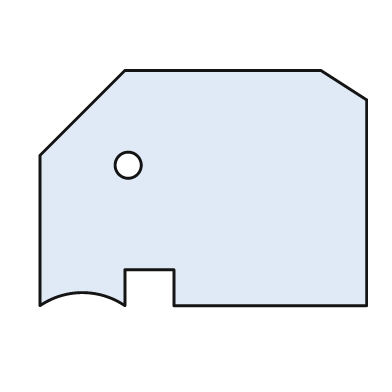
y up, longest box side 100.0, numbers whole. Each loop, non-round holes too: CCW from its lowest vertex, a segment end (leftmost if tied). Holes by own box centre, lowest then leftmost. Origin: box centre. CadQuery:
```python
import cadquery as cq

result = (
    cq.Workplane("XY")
    .moveTo(-50.0, -36.0)
    .threePointArc((-37.0, -32.0), (-24.0, -36.0))
    .lineTo(-24.0, -25.0)
    .lineTo(-9.0, -25.0)
    .lineTo(-9.0, -36.0)
    .lineTo(50.0, -36.0)
    .lineTo(50.0, 27.0)
    .lineTo(36.0, 36.0)
    .lineTo(-24.0, 36.0)
    .lineTo(-50.0, 10.0)
    .close()
    .moveTo(-23.0, 7.0)
    .circle(4.0)
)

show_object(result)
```